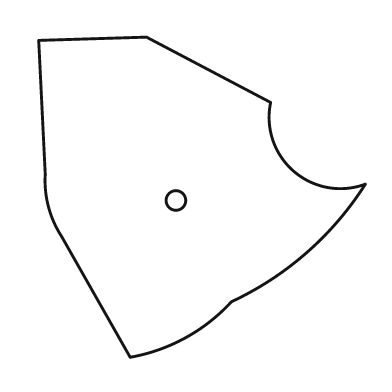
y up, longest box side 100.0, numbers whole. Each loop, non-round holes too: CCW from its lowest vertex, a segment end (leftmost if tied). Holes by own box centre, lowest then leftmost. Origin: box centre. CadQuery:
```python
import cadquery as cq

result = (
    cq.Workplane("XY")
    .moveTo(-22.0, -49.0)
    .threePointArc((-5.0, -43.0), (9.0, -32.0))
    .threePointArc((32.0, -17.0), (50.0, 4.0))
    .threePointArc((28.0, 8.0), (21.0, 29.0))
    .lineTo(-17.0, 49.0)
    .lineTo(-50.0, 48.0)
    .lineTo(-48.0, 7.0)
    .threePointArc((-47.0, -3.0), (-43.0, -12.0))
    .close()
    .moveTo(-8.0, -1.0)
    .circle(3.0)
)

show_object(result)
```